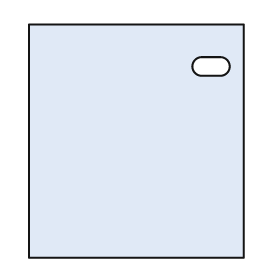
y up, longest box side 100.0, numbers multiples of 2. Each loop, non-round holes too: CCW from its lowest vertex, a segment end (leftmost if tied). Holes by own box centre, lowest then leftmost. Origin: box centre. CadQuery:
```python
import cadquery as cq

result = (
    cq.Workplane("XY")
    .moveTo(-46.0, -50.0)
    .lineTo(46.0, -50.0)
    .lineTo(46.0, 50.0)
    .lineTo(-46.0, 50.0)
    .close()
    .moveTo(28.0, 28.0)
    .lineTo(36.0, 28.0)
    .threePointArc((40.0, 32.0), (36.0, 36.0))
    .lineTo(28.0, 36.0)
    .threePointArc((24.0, 32.0), (28.0, 28.0))
    .close()
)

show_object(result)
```